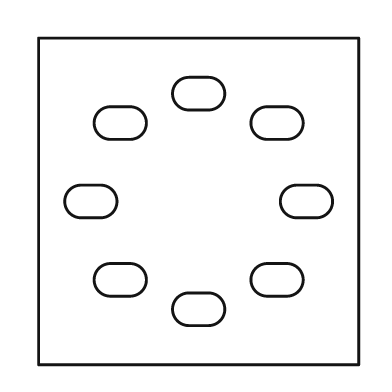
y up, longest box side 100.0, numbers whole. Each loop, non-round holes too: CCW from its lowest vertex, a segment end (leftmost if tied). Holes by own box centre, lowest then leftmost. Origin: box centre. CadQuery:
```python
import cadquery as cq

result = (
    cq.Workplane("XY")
    .moveTo(-49.0, -50.0)
    .lineTo(49.0, -50.0)
    .lineTo(49.0, 50.0)
    .lineTo(-49.0, 50.0)
    .close()
    .moveTo(-3.0, -38.0)
    .lineTo(3.0, -38.0)
    .threePointArc((8.0, -33.0), (3.0, -28.0))
    .lineTo(-3.0, -28.0)
    .threePointArc((-8.0, -33.0), (-3.0, -38.0))
    .close()
    .moveTo(-27.0, -29.0)
    .lineTo(-21.0, -29.0)
    .threePointArc((-16.0, -24.0), (-21.0, -19.0))
    .lineTo(-27.0, -19.0)
    .threePointArc((-32.0, -24.0), (-27.0, -29.0))
    .close()
    .moveTo(21.0, -29.0)
    .lineTo(27.0, -29.0)
    .threePointArc((32.0, -24.0), (27.0, -19.0))
    .lineTo(21.0, -19.0)
    .threePointArc((16.0, -24.0), (21.0, -29.0))
    .close()
    .moveTo(-36.0, -5.0)
    .lineTo(-30.0, -5.0)
    .threePointArc((-25.0, 0.0), (-30.0, 5.0))
    .lineTo(-36.0, 5.0)
    .threePointArc((-41.0, 0.0), (-36.0, -5.0))
    .close()
    .moveTo(30.0, -5.0)
    .lineTo(36.0, -5.0)
    .threePointArc((41.0, 0.0), (36.0, 5.0))
    .lineTo(30.0, 5.0)
    .threePointArc((25.0, 0.0), (30.0, -5.0))
    .close()
    .moveTo(-27.0, 19.0)
    .lineTo(-21.0, 19.0)
    .threePointArc((-16.0, 24.0), (-21.0, 29.0))
    .lineTo(-27.0, 29.0)
    .threePointArc((-32.0, 24.0), (-27.0, 19.0))
    .close()
    .moveTo(21.0, 19.0)
    .lineTo(27.0, 19.0)
    .threePointArc((32.0, 24.0), (27.0, 29.0))
    .lineTo(21.0, 29.0)
    .threePointArc((16.0, 24.0), (21.0, 19.0))
    .close()
    .moveTo(-3.0, 28.0)
    .lineTo(3.0, 28.0)
    .threePointArc((8.0, 33.0), (3.0, 38.0))
    .lineTo(-3.0, 38.0)
    .threePointArc((-8.0, 33.0), (-3.0, 28.0))
    .close()
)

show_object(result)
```